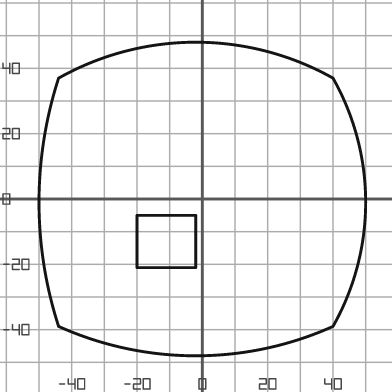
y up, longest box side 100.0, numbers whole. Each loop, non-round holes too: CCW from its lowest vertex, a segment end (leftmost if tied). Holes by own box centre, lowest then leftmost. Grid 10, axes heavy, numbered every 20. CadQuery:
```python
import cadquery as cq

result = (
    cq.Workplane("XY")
    .moveTo(-44.0, -39.0)
    .threePointArc((-2.0, -48.0), (40.0, -39.0))
    .threePointArc((50.0, -1.0), (40.0, 37.0))
    .threePointArc((-2.0, 48.0), (-44.0, 37.0))
    .threePointArc((-50.0, -1.0), (-44.0, -39.0))
    .close()
    .moveTo(-20.0, -21.0)
    .lineTo(-2.0, -21.0)
    .lineTo(-2.0, -5.0)
    .lineTo(-20.0, -5.0)
    .close()
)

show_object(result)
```